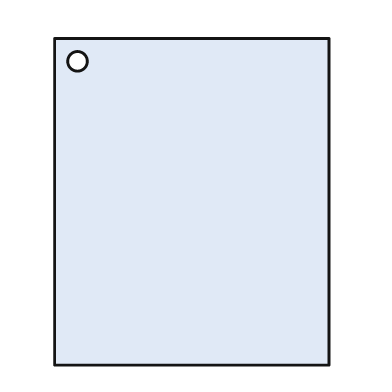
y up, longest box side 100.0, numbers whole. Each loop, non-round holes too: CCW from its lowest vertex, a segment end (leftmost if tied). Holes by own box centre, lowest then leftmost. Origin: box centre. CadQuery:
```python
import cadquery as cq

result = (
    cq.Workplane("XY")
    .moveTo(-42.0, -50.0)
    .lineTo(42.0, -50.0)
    .lineTo(42.0, 50.0)
    .lineTo(-42.0, 50.0)
    .close()
    .moveTo(-35.0, 43.0)
    .circle(3.0)
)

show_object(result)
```